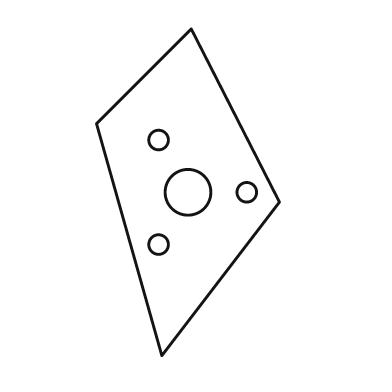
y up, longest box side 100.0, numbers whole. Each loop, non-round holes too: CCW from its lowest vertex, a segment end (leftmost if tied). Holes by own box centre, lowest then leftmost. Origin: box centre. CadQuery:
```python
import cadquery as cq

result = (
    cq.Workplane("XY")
    .moveTo(-8.0, -50.0)
    .lineTo(28.0, -3.0)
    .lineTo(1.0, 50.0)
    .lineTo(-28.0, 21.0)
    .close()
    .moveTo(-9.0, -16.0)
    .circle(3.0)
    .moveTo(0.0, 0.0)
    .circle(7.0)
    .moveTo(18.0, 0.0)
    .circle(3.0)
    .moveTo(-9.0, 16.0)
    .circle(3.0)
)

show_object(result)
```